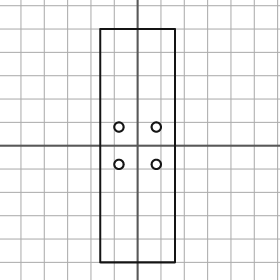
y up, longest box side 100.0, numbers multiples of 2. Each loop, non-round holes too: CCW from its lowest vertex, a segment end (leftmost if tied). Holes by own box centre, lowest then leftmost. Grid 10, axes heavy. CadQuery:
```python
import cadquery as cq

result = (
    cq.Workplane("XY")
    .moveTo(-16.0, -50.0)
    .lineTo(16.0, -50.0)
    .lineTo(16.0, 50.0)
    .lineTo(-16.0, 50.0)
    .close()
    .moveTo(-8.0, -8.0)
    .circle(2.0)
    .moveTo(8.0, -8.0)
    .circle(2.0)
    .moveTo(-8.0, 8.0)
    .circle(2.0)
    .moveTo(8.0, 8.0)
    .circle(2.0)
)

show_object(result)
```